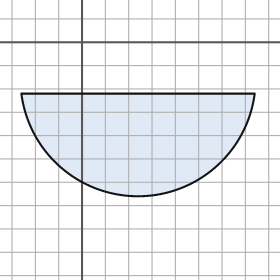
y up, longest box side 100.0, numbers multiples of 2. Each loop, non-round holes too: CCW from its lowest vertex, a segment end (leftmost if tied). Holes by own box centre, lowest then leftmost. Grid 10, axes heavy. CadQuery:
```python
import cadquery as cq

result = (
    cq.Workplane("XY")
    .moveTo(-26.0, -22.0)
    .threePointArc((24.0, -66.0), (74.0, -22.0))
    .close()
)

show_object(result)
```